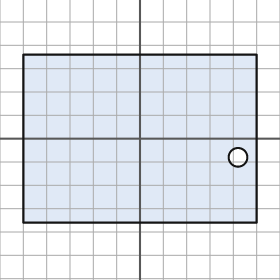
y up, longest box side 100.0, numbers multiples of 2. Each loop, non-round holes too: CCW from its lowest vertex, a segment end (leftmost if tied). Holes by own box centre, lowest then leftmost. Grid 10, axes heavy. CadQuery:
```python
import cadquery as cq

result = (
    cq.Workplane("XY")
    .moveTo(-50.0, -36.0)
    .lineTo(50.0, -36.0)
    .lineTo(50.0, 36.0)
    .lineTo(-50.0, 36.0)
    .close()
    .moveTo(42.0, -8.0)
    .circle(4.0)
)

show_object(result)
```